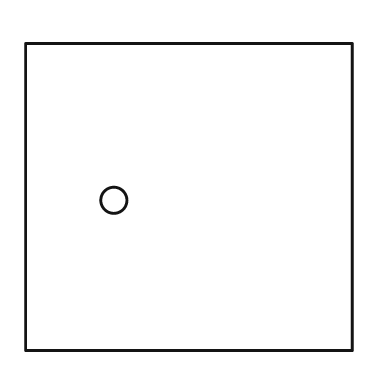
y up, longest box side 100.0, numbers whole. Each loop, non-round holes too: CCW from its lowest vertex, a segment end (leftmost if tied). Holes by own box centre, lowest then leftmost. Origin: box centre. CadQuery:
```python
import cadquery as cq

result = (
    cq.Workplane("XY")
    .moveTo(-50.0, -47.0)
    .lineTo(50.0, -47.0)
    .lineTo(50.0, 47.0)
    .lineTo(-50.0, 47.0)
    .close()
    .moveTo(-23.0, -1.0)
    .circle(4.0)
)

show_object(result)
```